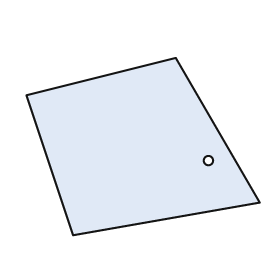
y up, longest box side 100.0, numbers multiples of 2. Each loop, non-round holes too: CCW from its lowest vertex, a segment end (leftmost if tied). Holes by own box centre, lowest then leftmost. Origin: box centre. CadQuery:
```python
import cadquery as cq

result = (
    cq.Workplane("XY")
    .moveTo(-30.0, -38.0)
    .lineTo(50.0, -24.0)
    .lineTo(14.0, 38.0)
    .lineTo(-50.0, 22.0)
    .close()
    .moveTo(28.0, -6.0)
    .circle(2.0)
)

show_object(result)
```